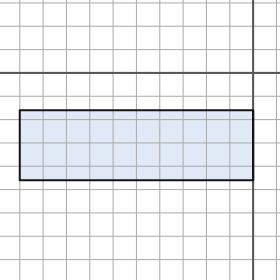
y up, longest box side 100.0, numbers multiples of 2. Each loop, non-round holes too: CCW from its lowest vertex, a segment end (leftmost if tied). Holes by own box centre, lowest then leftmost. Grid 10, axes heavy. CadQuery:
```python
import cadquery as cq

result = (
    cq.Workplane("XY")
    .moveTo(-100.0, -46.0)
    .lineTo(0.0, -46.0)
    .lineTo(0.0, -16.0)
    .lineTo(-100.0, -16.0)
    .close()
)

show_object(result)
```